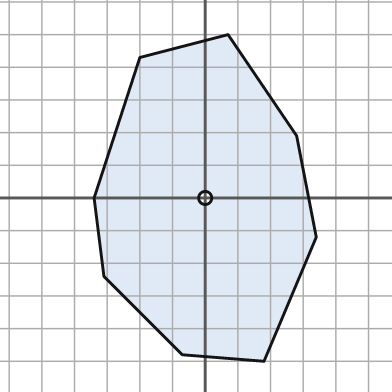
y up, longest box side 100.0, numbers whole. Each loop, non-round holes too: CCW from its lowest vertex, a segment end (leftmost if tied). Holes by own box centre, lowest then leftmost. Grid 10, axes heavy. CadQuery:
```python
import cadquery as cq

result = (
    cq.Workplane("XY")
    .moveTo(18.0, -50.0)
    .lineTo(34.0, -12.0)
    .lineTo(28.0, 19.0)
    .lineTo(7.0, 50.0)
    .lineTo(-20.0, 43.0)
    .lineTo(-34.0, 0.0)
    .lineTo(-31.0, -24.0)
    .lineTo(-7.0, -48.0)
    .close()
    .moveTo(0.0, 0.0)
    .circle(2.0)
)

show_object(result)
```